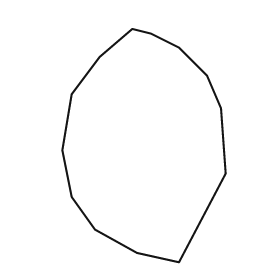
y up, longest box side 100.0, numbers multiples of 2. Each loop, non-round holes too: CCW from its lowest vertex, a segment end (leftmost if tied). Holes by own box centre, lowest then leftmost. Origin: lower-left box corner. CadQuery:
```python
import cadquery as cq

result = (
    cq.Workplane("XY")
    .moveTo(50.0, 0.0)
    .lineTo(70.0, 38.0)
    .lineTo(68.0, 66.0)
    .lineTo(62.0, 80.0)
    .lineTo(50.0, 92.0)
    .lineTo(38.0, 98.0)
    .lineTo(30.0, 100.0)
    .lineTo(16.0, 88.0)
    .lineTo(4.0, 72.0)
    .lineTo(0.0, 48.0)
    .lineTo(4.0, 28.0)
    .lineTo(14.0, 14.0)
    .lineTo(32.0, 4.0)
    .close()
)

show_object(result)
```